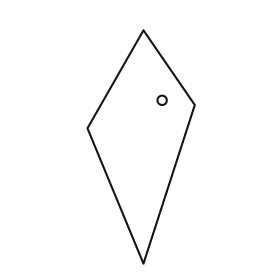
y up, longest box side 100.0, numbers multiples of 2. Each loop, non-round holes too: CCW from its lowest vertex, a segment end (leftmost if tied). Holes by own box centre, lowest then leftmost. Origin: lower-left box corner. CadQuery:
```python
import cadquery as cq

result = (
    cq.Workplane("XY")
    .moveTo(24.0, 0.0)
    .lineTo(46.0, 68.0)
    .lineTo(24.0, 100.0)
    .lineTo(0.0, 58.0)
    .close()
    .moveTo(32.0, 70.0)
    .circle(2.0)
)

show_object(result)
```